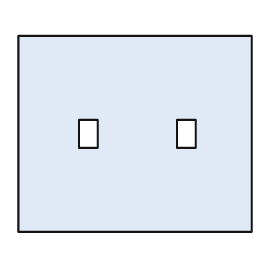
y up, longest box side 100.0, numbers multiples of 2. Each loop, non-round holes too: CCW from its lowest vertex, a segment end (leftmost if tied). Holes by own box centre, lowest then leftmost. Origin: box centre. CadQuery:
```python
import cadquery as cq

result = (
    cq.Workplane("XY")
    .moveTo(-50.0, -42.0)
    .lineTo(50.0, -42.0)
    .lineTo(50.0, 42.0)
    .lineTo(-50.0, 42.0)
    .close()
    .moveTo(-24.0, -6.0)
    .lineTo(-16.0, -6.0)
    .lineTo(-16.0, 6.0)
    .lineTo(-24.0, 6.0)
    .close()
    .moveTo(18.0, -6.0)
    .lineTo(26.0, -6.0)
    .lineTo(26.0, 6.0)
    .lineTo(18.0, 6.0)
    .close()
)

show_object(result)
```